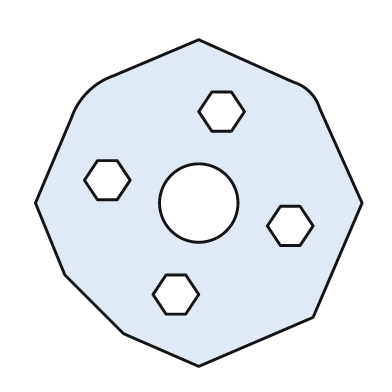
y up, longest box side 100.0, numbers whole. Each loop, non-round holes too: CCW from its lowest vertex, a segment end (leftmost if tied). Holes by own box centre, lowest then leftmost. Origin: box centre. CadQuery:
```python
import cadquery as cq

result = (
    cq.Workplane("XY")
    .moveTo(0.0, -50.0)
    .lineTo(35.0, -35.0)
    .lineTo(50.0, 0.0)
    .lineTo(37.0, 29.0)
    .threePointArc((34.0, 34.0), (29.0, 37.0))
    .lineTo(0.0, 50.0)
    .lineTo(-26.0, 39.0)
    .threePointArc((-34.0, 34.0), (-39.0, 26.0))
    .lineTo(-50.0, 0.0)
    .lineTo(-41.0, -22.0)
    .lineTo(-23.0, -40.0)
    .close()
    .moveTo(-10.0, -34.0)
    .lineTo(-4.0, -34.0)
    .lineTo(0.0, -28.0)
    .lineTo(-4.0, -22.0)
    .lineTo(-10.0, -22.0)
    .lineTo(-14.0, -28.0)
    .close()
    .moveTo(25.0, -13.0)
    .lineTo(31.0, -13.0)
    .lineTo(35.0, -7.0)
    .lineTo(31.0, -1.0)
    .lineTo(25.0, -1.0)
    .lineTo(21.0, -7.0)
    .close()
    .moveTo(0.0, 0.0)
    .circle(12.0)
    .moveTo(-31.0, 1.0)
    .lineTo(-25.0, 1.0)
    .lineTo(-21.0, 7.0)
    .lineTo(-25.0, 13.0)
    .lineTo(-31.0, 13.0)
    .lineTo(-35.0, 7.0)
    .close()
    .moveTo(4.0, 22.0)
    .lineTo(10.0, 22.0)
    .lineTo(14.0, 28.0)
    .lineTo(10.0, 34.0)
    .lineTo(4.0, 34.0)
    .lineTo(0.0, 28.0)
    .close()
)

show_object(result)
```